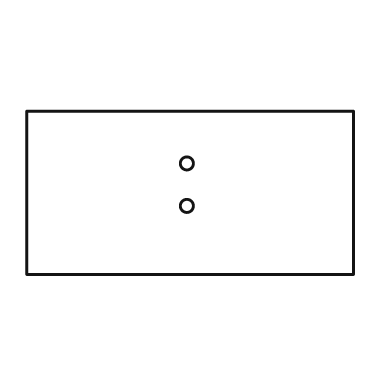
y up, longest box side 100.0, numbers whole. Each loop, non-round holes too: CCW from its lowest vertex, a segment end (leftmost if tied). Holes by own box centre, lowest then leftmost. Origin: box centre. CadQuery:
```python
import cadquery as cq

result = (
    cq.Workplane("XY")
    .moveTo(-50.0, -25.0)
    .lineTo(50.0, -25.0)
    .lineTo(50.0, 25.0)
    .lineTo(-50.0, 25.0)
    .close()
    .moveTo(-1.0, -4.0)
    .circle(2.0)
    .moveTo(-1.0, 9.0)
    .circle(2.0)
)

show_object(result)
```